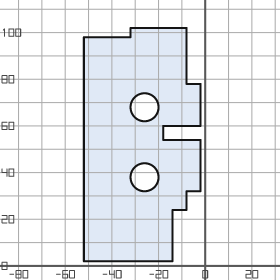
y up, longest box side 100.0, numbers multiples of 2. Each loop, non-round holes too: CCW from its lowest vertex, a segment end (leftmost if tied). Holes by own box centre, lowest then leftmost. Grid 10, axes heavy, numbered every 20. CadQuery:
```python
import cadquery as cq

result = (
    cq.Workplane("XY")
    .moveTo(-52.0, 2.0)
    .lineTo(-14.0, 2.0)
    .lineTo(-14.0, 24.0)
    .lineTo(-8.0, 24.0)
    .lineTo(-8.0, 32.0)
    .lineTo(-2.0, 32.0)
    .lineTo(-2.0, 54.0)
    .lineTo(-18.0, 54.0)
    .lineTo(-18.0, 60.0)
    .lineTo(-2.0, 60.0)
    .lineTo(-2.0, 78.0)
    .lineTo(-8.0, 78.0)
    .lineTo(-8.0, 102.0)
    .lineTo(-32.0, 102.0)
    .lineTo(-32.0, 98.0)
    .lineTo(-52.0, 98.0)
    .close()
    .moveTo(-26.0, 38.0)
    .circle(6.0)
    .moveTo(-26.0, 68.0)
    .circle(6.0)
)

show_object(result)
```